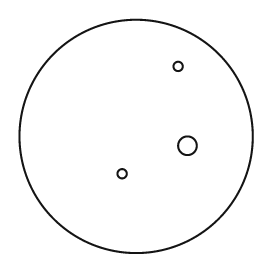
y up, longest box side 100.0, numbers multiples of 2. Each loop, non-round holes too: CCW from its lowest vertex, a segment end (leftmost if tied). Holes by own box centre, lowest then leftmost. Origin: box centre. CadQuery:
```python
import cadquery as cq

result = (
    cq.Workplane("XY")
    .moveTo(0.0, 0.0)
    .circle(50.0)
    .moveTo(-6.0, -16.0)
    .circle(2.0)
    .moveTo(22.0, -4.0)
    .circle(4.0)
    .moveTo(18.0, 30.0)
    .circle(2.0)
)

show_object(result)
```